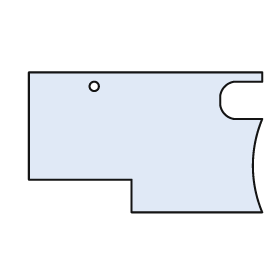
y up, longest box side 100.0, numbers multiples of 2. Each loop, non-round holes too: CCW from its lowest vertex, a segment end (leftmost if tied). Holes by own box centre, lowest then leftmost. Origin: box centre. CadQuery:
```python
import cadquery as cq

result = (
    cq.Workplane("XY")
    .moveTo(-6.0, -30.0)
    .lineTo(50.0, -30.0)
    .threePointArc((46.0, -10.0), (50.0, 10.0))
    .lineTo(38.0, 10.0)
    .threePointArc((34.0, 12.0), (32.0, 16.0))
    .lineTo(32.0, 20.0)
    .threePointArc((34.0, 24.0), (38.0, 26.0))
    .lineTo(50.0, 26.0)
    .lineTo(50.0, 30.0)
    .lineTo(-50.0, 30.0)
    .lineTo(-50.0, -16.0)
    .lineTo(-6.0, -16.0)
    .close()
    .moveTo(-22.0, 24.0)
    .circle(2.0)
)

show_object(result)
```